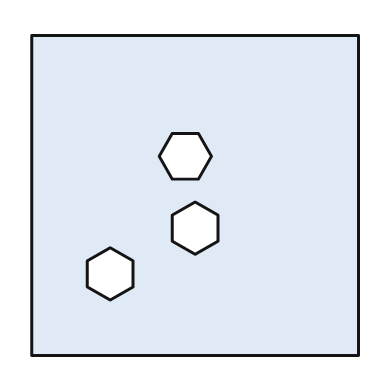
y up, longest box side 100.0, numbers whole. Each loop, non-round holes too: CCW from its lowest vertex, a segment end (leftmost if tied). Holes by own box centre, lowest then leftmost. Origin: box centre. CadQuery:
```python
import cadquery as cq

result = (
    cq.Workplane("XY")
    .moveTo(-50.0, -49.0)
    .lineTo(50.0, -49.0)
    .lineTo(50.0, 49.0)
    .lineTo(-50.0, 49.0)
    .close()
    .moveTo(-26.0, -32.0)
    .lineTo(-19.0, -28.0)
    .lineTo(-19.0, -20.0)
    .lineTo(-26.0, -16.0)
    .lineTo(-33.0, -20.0)
    .lineTo(-33.0, -28.0)
    .close()
    .moveTo(0.0, -18.0)
    .lineTo(7.0, -14.0)
    .lineTo(7.0, -6.0)
    .lineTo(0.0, -2.0)
    .lineTo(-7.0, -6.0)
    .lineTo(-7.0, -14.0)
    .close()
    .moveTo(-7.0, 5.0)
    .lineTo(1.0, 5.0)
    .lineTo(5.0, 12.0)
    .lineTo(1.0, 19.0)
    .lineTo(-7.0, 19.0)
    .lineTo(-11.0, 12.0)
    .close()
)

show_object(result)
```